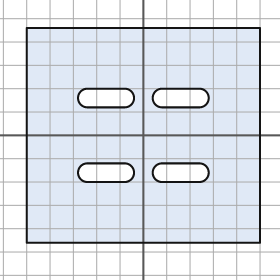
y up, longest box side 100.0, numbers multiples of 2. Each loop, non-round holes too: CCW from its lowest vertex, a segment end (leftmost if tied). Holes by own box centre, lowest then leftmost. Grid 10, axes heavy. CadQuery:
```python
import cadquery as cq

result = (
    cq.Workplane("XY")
    .moveTo(-50.0, -46.0)
    .lineTo(50.0, -46.0)
    .lineTo(50.0, 46.0)
    .lineTo(-50.0, 46.0)
    .close()
    .moveTo(-24.0, -20.0)
    .lineTo(-8.0, -20.0)
    .threePointArc((-4.0, -16.0), (-8.0, -12.0))
    .lineTo(-24.0, -12.0)
    .threePointArc((-28.0, -16.0), (-24.0, -20.0))
    .close()
    .moveTo(8.0, -20.0)
    .lineTo(24.0, -20.0)
    .threePointArc((28.0, -16.0), (24.0, -12.0))
    .lineTo(8.0, -12.0)
    .threePointArc((4.0, -16.0), (8.0, -20.0))
    .close()
    .moveTo(-24.0, 12.0)
    .lineTo(-8.0, 12.0)
    .threePointArc((-4.0, 16.0), (-8.0, 20.0))
    .lineTo(-24.0, 20.0)
    .threePointArc((-28.0, 16.0), (-24.0, 12.0))
    .close()
    .moveTo(8.0, 12.0)
    .lineTo(24.0, 12.0)
    .threePointArc((28.0, 16.0), (24.0, 20.0))
    .lineTo(8.0, 20.0)
    .threePointArc((4.0, 16.0), (8.0, 12.0))
    .close()
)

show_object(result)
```